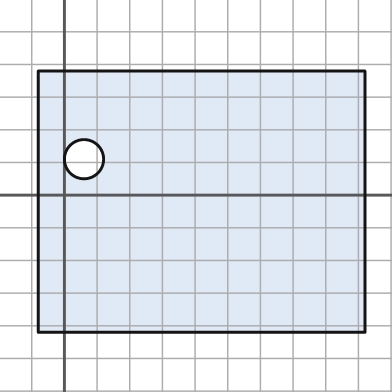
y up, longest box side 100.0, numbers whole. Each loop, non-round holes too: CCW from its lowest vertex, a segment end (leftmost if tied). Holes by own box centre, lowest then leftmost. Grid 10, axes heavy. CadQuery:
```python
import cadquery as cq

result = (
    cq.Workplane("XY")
    .moveTo(-8.0, -42.0)
    .lineTo(92.0, -42.0)
    .lineTo(92.0, 38.0)
    .lineTo(-8.0, 38.0)
    .close()
    .moveTo(6.0, 11.0)
    .circle(6.0)
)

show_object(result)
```